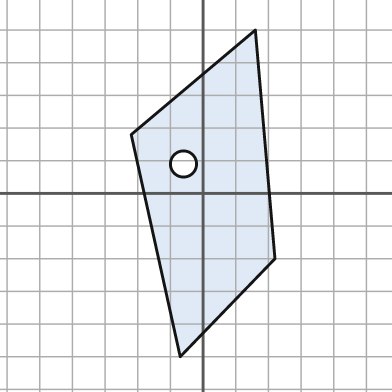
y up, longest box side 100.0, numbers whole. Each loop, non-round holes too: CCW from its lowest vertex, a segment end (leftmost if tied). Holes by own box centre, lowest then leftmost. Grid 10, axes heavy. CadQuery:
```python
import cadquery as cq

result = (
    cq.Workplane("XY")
    .moveTo(-7.0, -50.0)
    .lineTo(22.0, -20.0)
    .lineTo(16.0, 50.0)
    .lineTo(-22.0, 18.0)
    .close()
    .moveTo(-6.0, 9.0)
    .circle(4.0)
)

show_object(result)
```